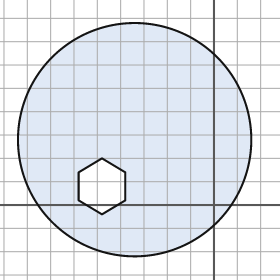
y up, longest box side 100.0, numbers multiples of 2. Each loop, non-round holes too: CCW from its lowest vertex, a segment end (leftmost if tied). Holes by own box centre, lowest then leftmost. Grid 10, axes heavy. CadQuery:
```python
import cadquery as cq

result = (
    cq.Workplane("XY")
    .moveTo(-34.0, 28.0)
    .circle(50.0)
    .moveTo(-48.0, -4.0)
    .lineTo(-38.0, 2.0)
    .lineTo(-38.0, 14.0)
    .lineTo(-48.0, 20.0)
    .lineTo(-58.0, 14.0)
    .lineTo(-58.0, 2.0)
    .close()
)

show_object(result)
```